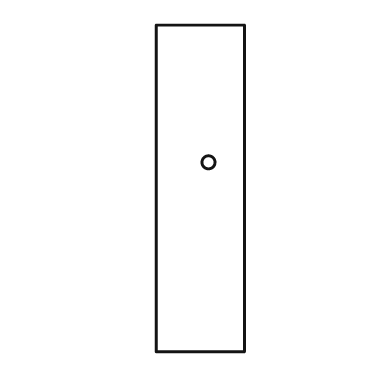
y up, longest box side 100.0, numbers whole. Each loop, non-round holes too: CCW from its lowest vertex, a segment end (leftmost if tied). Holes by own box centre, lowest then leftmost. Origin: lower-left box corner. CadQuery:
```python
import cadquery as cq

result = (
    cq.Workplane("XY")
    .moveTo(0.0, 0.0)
    .lineTo(27.0, 0.0)
    .lineTo(27.0, 100.0)
    .lineTo(0.0, 100.0)
    .close()
    .moveTo(16.0, 58.0)
    .circle(2.0)
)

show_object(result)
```